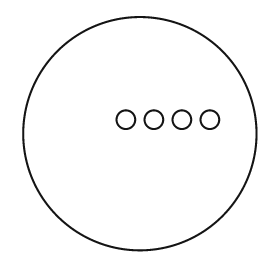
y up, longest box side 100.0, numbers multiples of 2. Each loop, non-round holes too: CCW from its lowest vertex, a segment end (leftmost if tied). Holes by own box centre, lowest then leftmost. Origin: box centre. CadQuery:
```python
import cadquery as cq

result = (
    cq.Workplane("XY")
    .moveTo(0.0, 0.0)
    .circle(50.0)
    .moveTo(-6.0, 6.0)
    .circle(4.0)
    .moveTo(6.0, 6.0)
    .circle(4.0)
    .moveTo(18.0, 6.0)
    .circle(4.0)
    .moveTo(30.0, 6.0)
    .circle(4.0)
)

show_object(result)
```